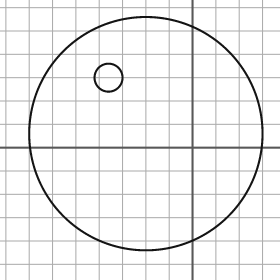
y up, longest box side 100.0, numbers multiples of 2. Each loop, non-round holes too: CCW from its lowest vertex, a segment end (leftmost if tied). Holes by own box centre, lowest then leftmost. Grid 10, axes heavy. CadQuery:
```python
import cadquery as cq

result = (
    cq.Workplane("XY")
    .moveTo(-20.0, 6.0)
    .circle(50.0)
    .moveTo(-36.0, 30.0)
    .circle(6.0)
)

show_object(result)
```